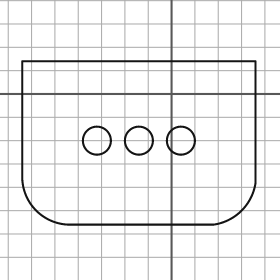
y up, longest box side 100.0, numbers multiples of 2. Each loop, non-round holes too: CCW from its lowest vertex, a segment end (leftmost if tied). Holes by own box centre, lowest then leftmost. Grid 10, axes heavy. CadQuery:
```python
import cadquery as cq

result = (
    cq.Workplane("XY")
    .moveTo(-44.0, -56.0)
    .lineTo(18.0, -56.0)
    .threePointArc((30.0, -50.0), (36.0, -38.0))
    .lineTo(36.0, 14.0)
    .lineTo(-64.0, 14.0)
    .lineTo(-64.0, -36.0)
    .threePointArc((-58.0, -50.0), (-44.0, -56.0))
    .close()
    .moveTo(-32.0, -20.0)
    .circle(6.0)
    .moveTo(-14.0, -20.0)
    .circle(6.0)
    .moveTo(4.0, -20.0)
    .circle(6.0)
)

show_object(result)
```